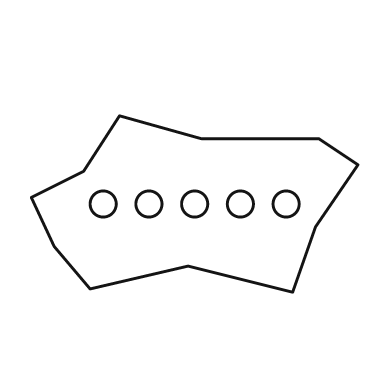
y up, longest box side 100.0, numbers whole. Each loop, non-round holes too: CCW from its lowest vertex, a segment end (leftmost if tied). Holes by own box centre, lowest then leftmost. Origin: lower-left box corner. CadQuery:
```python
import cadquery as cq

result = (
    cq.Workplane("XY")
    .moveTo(80.0, 0.0)
    .lineTo(87.0, 20.0)
    .lineTo(100.0, 39.0)
    .lineTo(88.0, 47.0)
    .lineTo(52.0, 47.0)
    .lineTo(27.0, 54.0)
    .lineTo(16.0, 37.0)
    .lineTo(0.0, 29.0)
    .lineTo(7.0, 14.0)
    .lineTo(18.0, 1.0)
    .lineTo(48.0, 8.0)
    .close()
    .moveTo(22.0, 27.0)
    .circle(4.0)
    .moveTo(36.0, 27.0)
    .circle(4.0)
    .moveTo(50.0, 27.0)
    .circle(4.0)
    .moveTo(64.0, 27.0)
    .circle(4.0)
    .moveTo(78.0, 27.0)
    .circle(4.0)
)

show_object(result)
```